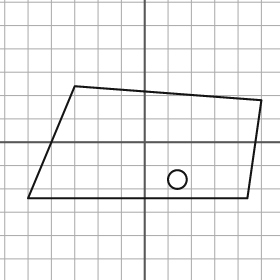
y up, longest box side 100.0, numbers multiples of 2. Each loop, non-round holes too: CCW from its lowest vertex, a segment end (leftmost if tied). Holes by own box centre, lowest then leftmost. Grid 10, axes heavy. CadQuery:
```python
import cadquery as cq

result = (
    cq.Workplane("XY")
    .moveTo(-50.0, -24.0)
    .lineTo(44.0, -24.0)
    .lineTo(50.0, 18.0)
    .lineTo(-30.0, 24.0)
    .close()
    .moveTo(14.0, -16.0)
    .circle(4.0)
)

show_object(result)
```